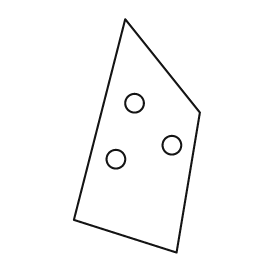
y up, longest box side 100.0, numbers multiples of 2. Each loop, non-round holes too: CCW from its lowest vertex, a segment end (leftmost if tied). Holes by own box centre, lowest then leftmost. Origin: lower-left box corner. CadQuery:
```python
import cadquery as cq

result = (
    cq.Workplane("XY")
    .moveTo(44.0, 0.0)
    .lineTo(54.0, 60.0)
    .lineTo(22.0, 100.0)
    .lineTo(0.0, 14.0)
    .close()
    .moveTo(18.0, 40.0)
    .circle(4.0)
    .moveTo(42.0, 46.0)
    .circle(4.0)
    .moveTo(26.0, 64.0)
    .circle(4.0)
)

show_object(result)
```